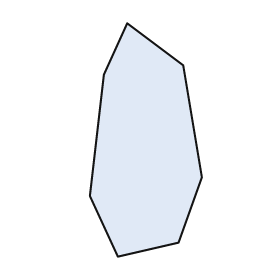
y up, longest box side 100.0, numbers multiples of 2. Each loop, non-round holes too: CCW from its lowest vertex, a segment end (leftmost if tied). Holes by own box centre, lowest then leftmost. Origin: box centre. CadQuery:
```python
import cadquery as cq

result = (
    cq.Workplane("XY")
    .moveTo(-12.0, -50.0)
    .lineTo(14.0, -44.0)
    .lineTo(24.0, -16.0)
    .lineTo(16.0, 32.0)
    .lineTo(-8.0, 50.0)
    .lineTo(-18.0, 28.0)
    .lineTo(-24.0, -24.0)
    .close()
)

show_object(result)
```